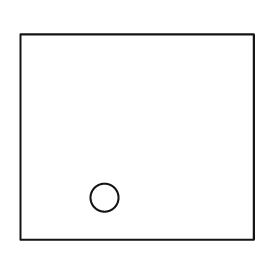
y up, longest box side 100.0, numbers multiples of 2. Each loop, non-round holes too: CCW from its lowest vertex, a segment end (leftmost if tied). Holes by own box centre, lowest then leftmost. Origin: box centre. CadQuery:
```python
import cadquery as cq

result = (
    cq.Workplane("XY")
    .moveTo(-50.0, -44.0)
    .lineTo(50.0, -44.0)
    .lineTo(50.0, 44.0)
    .lineTo(-50.0, 44.0)
    .close()
    .moveTo(-14.0, -26.0)
    .circle(6.0)
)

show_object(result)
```